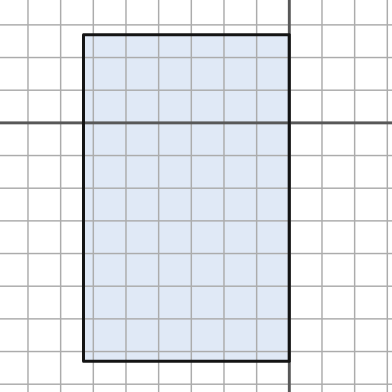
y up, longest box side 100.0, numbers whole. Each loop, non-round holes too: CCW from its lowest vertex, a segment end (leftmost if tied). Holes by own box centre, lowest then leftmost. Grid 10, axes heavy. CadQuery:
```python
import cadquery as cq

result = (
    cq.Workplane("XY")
    .moveTo(-63.0, -73.0)
    .lineTo(0.0, -73.0)
    .lineTo(0.0, 27.0)
    .lineTo(-63.0, 27.0)
    .close()
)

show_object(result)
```